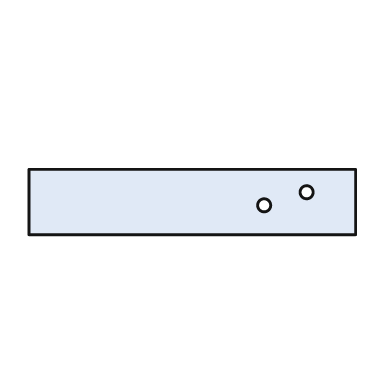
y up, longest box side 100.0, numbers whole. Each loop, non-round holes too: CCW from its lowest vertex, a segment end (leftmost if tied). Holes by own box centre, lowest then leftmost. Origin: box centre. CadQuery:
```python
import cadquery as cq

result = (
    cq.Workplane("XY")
    .moveTo(-50.0, -10.0)
    .lineTo(50.0, -10.0)
    .lineTo(50.0, 10.0)
    .lineTo(-50.0, 10.0)
    .close()
    .moveTo(22.0, -1.0)
    .circle(2.0)
    .moveTo(35.0, 3.0)
    .circle(2.0)
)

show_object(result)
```